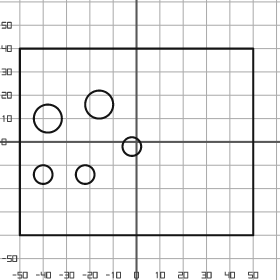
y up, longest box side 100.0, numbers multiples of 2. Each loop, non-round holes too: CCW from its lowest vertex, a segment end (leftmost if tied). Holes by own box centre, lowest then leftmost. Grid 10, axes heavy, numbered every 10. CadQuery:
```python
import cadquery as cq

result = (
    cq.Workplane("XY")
    .moveTo(-50.0, -40.0)
    .lineTo(50.0, -40.0)
    .lineTo(50.0, 40.0)
    .lineTo(-50.0, 40.0)
    .close()
    .moveTo(-40.0, -14.0)
    .circle(4.0)
    .moveTo(-22.0, -14.0)
    .circle(4.0)
    .moveTo(-2.0, -2.0)
    .circle(4.0)
    .moveTo(-38.0, 10.0)
    .circle(6.0)
    .moveTo(-16.0, 16.0)
    .circle(6.0)
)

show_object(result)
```